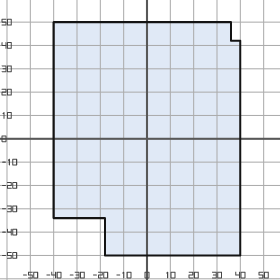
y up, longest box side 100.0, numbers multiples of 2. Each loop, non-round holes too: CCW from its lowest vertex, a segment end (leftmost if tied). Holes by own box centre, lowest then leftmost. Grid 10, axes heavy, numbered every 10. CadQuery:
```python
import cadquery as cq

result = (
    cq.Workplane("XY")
    .moveTo(-18.0, -50.0)
    .lineTo(40.0, -50.0)
    .lineTo(40.0, 42.0)
    .lineTo(36.0, 42.0)
    .lineTo(36.0, 50.0)
    .lineTo(-40.0, 50.0)
    .lineTo(-40.0, -34.0)
    .lineTo(-18.0, -34.0)
    .close()
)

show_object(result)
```